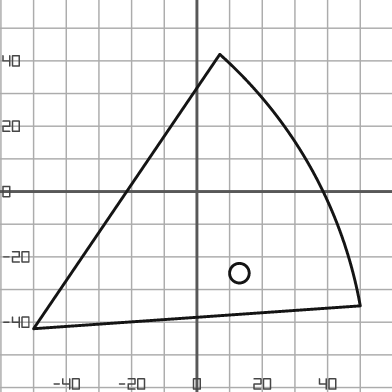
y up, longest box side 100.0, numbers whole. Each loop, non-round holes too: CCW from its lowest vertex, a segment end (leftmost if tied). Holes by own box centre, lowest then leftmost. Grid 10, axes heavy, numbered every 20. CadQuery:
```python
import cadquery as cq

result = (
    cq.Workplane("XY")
    .moveTo(-50.0, -42.0)
    .lineTo(50.0, -35.0)
    .threePointArc((35.0, 7.0), (7.0, 42.0))
    .close()
    .moveTo(13.0, -25.0)
    .circle(3.0)
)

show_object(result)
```